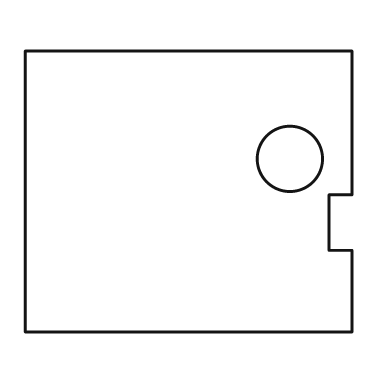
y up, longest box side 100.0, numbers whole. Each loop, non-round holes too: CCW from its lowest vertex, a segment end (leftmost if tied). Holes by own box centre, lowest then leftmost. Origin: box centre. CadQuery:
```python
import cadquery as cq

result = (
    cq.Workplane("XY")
    .moveTo(-50.0, -43.0)
    .lineTo(50.0, -43.0)
    .lineTo(50.0, -18.0)
    .lineTo(43.0, -18.0)
    .lineTo(43.0, -1.0)
    .lineTo(50.0, -1.0)
    .lineTo(50.0, 43.0)
    .lineTo(-50.0, 43.0)
    .close()
    .moveTo(31.0, 10.0)
    .circle(10.0)
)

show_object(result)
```